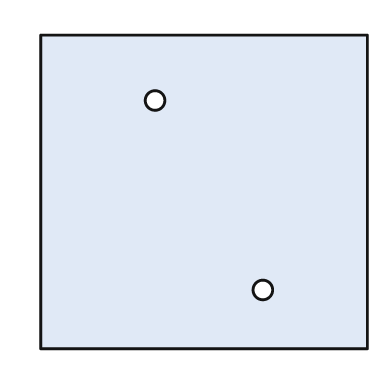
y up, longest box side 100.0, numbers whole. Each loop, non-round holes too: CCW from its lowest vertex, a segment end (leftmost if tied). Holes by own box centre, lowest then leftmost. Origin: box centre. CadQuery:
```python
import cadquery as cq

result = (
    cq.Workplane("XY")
    .moveTo(-50.0, -48.0)
    .lineTo(50.0, -48.0)
    .lineTo(50.0, 48.0)
    .lineTo(-50.0, 48.0)
    .close()
    .moveTo(18.0, -30.0)
    .circle(3.0)
    .moveTo(-15.0, 28.0)
    .circle(3.0)
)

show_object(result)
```